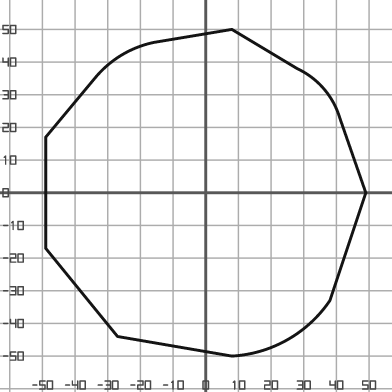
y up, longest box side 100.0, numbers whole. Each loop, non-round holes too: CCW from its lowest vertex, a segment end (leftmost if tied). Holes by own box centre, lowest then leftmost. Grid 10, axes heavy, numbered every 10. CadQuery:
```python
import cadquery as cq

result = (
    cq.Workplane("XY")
    .moveTo(8.0, -50.0)
    .threePointArc((25.0, -45.0), (38.0, -33.0))
    .lineTo(49.0, 0.0)
    .lineTo(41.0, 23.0)
    .threePointArc((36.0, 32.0), (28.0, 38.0))
    .lineTo(8.0, 50.0)
    .lineTo(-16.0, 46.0)
    .threePointArc((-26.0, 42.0), (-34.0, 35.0))
    .lineTo(-49.0, 17.0)
    .lineTo(-49.0, -17.0)
    .lineTo(-27.0, -44.0)
    .close()
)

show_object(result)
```